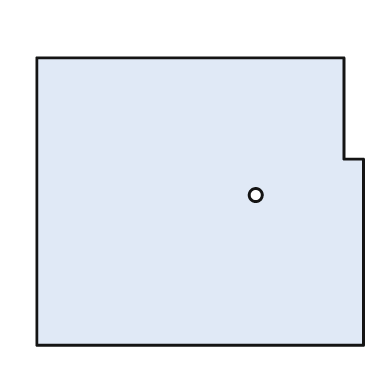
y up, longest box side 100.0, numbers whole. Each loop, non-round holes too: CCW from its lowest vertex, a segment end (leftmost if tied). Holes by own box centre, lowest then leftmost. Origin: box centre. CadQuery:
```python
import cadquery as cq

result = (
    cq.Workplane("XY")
    .moveTo(-50.0, -44.0)
    .lineTo(50.0, -44.0)
    .lineTo(50.0, 13.0)
    .lineTo(44.0, 13.0)
    .lineTo(44.0, 44.0)
    .lineTo(-50.0, 44.0)
    .close()
    .moveTo(17.0, 2.0)
    .circle(2.0)
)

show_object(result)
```